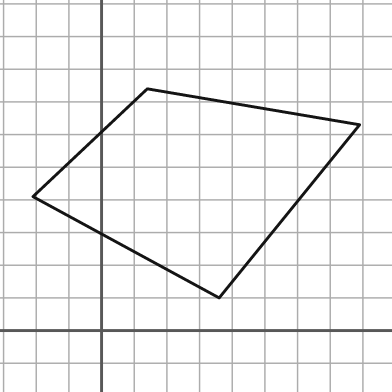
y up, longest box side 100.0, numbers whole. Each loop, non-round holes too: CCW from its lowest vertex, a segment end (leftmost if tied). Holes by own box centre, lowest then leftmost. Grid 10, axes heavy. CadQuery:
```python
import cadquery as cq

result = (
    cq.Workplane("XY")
    .moveTo(36.0, 10.0)
    .lineTo(79.0, 63.0)
    .lineTo(14.0, 74.0)
    .lineTo(-21.0, 41.0)
    .close()
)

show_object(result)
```